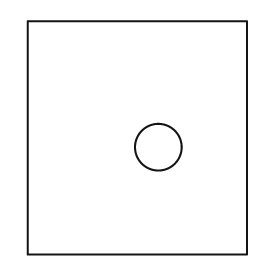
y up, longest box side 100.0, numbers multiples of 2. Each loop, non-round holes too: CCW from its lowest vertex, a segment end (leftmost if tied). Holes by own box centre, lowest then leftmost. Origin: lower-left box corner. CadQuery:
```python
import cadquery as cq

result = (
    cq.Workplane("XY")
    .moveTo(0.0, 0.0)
    .lineTo(94.0, 0.0)
    .lineTo(94.0, 100.0)
    .lineTo(0.0, 100.0)
    .close()
    .moveTo(56.0, 46.0)
    .circle(10.0)
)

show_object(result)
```